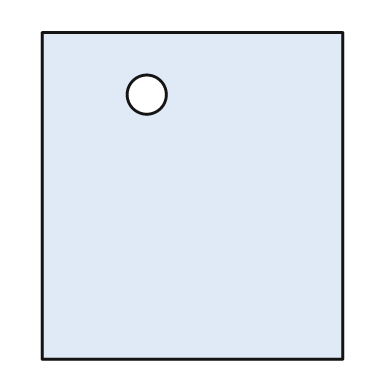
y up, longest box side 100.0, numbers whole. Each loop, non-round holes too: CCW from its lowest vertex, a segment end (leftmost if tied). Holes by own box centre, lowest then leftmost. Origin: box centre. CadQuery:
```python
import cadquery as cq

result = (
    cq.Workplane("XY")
    .moveTo(-46.0, -50.0)
    .lineTo(46.0, -50.0)
    .lineTo(46.0, 50.0)
    .lineTo(-46.0, 50.0)
    .close()
    .moveTo(-14.0, 31.0)
    .circle(6.0)
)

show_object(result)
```